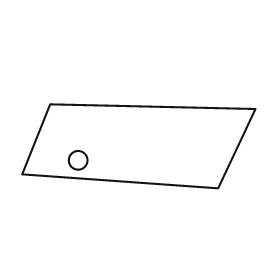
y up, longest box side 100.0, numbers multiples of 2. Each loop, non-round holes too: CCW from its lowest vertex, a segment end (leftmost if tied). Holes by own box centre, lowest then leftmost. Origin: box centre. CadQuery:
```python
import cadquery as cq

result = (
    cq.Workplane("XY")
    .moveTo(34.0, -18.0)
    .lineTo(50.0, 16.0)
    .lineTo(-38.0, 18.0)
    .lineTo(-50.0, -12.0)
    .close()
    .moveTo(-26.0, -6.0)
    .circle(4.0)
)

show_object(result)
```